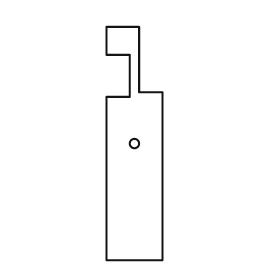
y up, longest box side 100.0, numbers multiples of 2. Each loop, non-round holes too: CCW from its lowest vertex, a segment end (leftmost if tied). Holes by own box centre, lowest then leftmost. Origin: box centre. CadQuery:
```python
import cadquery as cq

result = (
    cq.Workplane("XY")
    .moveTo(-12.0, -50.0)
    .lineTo(12.0, -50.0)
    .lineTo(12.0, 22.0)
    .lineTo(2.0, 22.0)
    .lineTo(2.0, 50.0)
    .lineTo(-12.0, 50.0)
    .lineTo(-12.0, 38.0)
    .lineTo(-2.0, 38.0)
    .lineTo(-2.0, 20.0)
    .lineTo(-12.0, 20.0)
    .close()
    .moveTo(0.0, 0.0)
    .circle(2.0)
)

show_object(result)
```